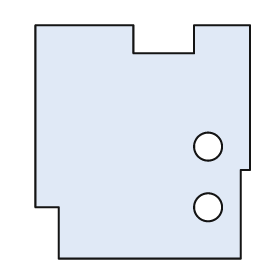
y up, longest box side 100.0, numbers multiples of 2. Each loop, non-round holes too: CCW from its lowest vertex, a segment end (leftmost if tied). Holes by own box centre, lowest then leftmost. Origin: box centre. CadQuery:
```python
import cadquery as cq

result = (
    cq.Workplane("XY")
    .moveTo(-36.0, -50.0)
    .lineTo(42.0, -50.0)
    .lineTo(42.0, -12.0)
    .lineTo(46.0, -12.0)
    .lineTo(46.0, 50.0)
    .lineTo(22.0, 50.0)
    .lineTo(22.0, 38.0)
    .lineTo(-4.0, 38.0)
    .lineTo(-4.0, 50.0)
    .lineTo(-46.0, 50.0)
    .lineTo(-46.0, -28.0)
    .lineTo(-36.0, -28.0)
    .close()
    .moveTo(28.0, -28.0)
    .circle(6.0)
    .moveTo(28.0, -2.0)
    .circle(6.0)
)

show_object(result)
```